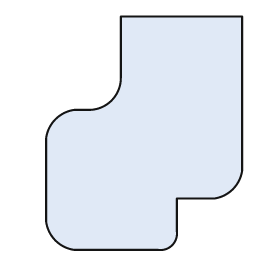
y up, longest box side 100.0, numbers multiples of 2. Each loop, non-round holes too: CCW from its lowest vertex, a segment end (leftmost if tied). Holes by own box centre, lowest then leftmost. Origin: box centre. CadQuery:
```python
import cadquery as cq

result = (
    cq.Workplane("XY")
    .moveTo(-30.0, -50.0)
    .lineTo(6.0, -50.0)
    .threePointArc((12.0, -48.0), (14.0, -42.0))
    .lineTo(14.0, -28.0)
    .lineTo(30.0, -28.0)
    .threePointArc((38.0, -24.0), (42.0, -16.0))
    .lineTo(42.0, 50.0)
    .lineTo(-10.0, 50.0)
    .lineTo(-10.0, 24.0)
    .threePointArc((-14.0, 14.0), (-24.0, 10.0))
    .lineTo(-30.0, 10.0)
    .threePointArc((-38.0, 6.0), (-42.0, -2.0))
    .lineTo(-42.0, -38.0)
    .threePointArc((-38.0, -46.0), (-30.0, -50.0))
    .close()
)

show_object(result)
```